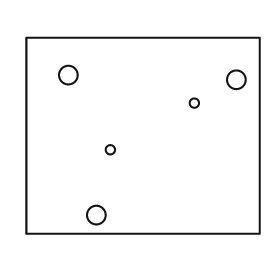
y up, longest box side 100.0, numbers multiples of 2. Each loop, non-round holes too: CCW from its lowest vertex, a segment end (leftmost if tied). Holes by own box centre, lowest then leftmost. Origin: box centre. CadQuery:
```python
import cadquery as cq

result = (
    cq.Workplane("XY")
    .moveTo(-50.0, -42.0)
    .lineTo(50.0, -42.0)
    .lineTo(50.0, 42.0)
    .lineTo(-50.0, 42.0)
    .close()
    .moveTo(-20.0, -34.0)
    .circle(4.0)
    .moveTo(-14.0, -6.0)
    .circle(2.0)
    .moveTo(22.0, 14.0)
    .circle(2.0)
    .moveTo(40.0, 24.0)
    .circle(4.0)
    .moveTo(-32.0, 26.0)
    .circle(4.0)
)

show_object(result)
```